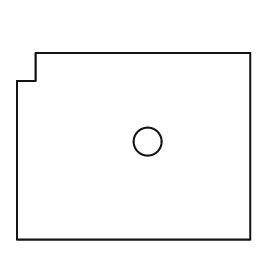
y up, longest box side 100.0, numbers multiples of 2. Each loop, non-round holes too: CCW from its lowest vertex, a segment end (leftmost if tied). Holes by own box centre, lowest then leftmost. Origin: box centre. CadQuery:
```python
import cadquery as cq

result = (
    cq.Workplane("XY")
    .moveTo(-50.0, -40.0)
    .lineTo(50.0, -40.0)
    .lineTo(50.0, 40.0)
    .lineTo(-42.0, 40.0)
    .lineTo(-42.0, 28.0)
    .lineTo(-50.0, 28.0)
    .close()
    .moveTo(6.0, 2.0)
    .circle(6.0)
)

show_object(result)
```